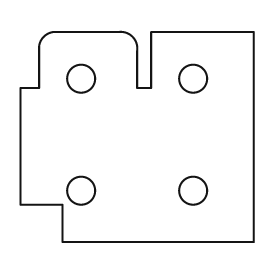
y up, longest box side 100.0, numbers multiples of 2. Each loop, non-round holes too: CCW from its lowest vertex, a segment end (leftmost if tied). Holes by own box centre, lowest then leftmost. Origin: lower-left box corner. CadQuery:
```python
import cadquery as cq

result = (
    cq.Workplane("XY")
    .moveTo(18.0, 0.0)
    .lineTo(100.0, 0.0)
    .lineTo(100.0, 90.0)
    .lineTo(56.0, 90.0)
    .lineTo(56.0, 66.0)
    .lineTo(50.0, 66.0)
    .lineTo(50.0, 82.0)
    .threePointArc((48.0, 88.0), (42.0, 90.0))
    .lineTo(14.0, 90.0)
    .threePointArc((10.0, 88.0), (8.0, 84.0))
    .lineTo(8.0, 66.0)
    .lineTo(0.0, 66.0)
    .lineTo(0.0, 16.0)
    .lineTo(18.0, 16.0)
    .close()
    .moveTo(26.0, 22.0)
    .circle(6.0)
    .moveTo(74.0, 22.0)
    .circle(6.0)
    .moveTo(26.0, 70.0)
    .circle(6.0)
    .moveTo(74.0, 70.0)
    .circle(6.0)
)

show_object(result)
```